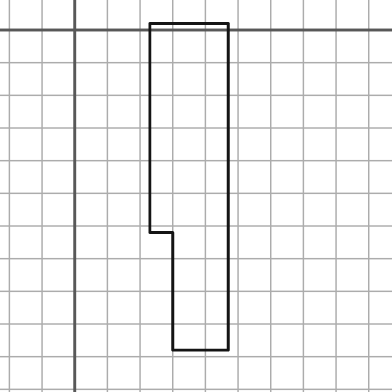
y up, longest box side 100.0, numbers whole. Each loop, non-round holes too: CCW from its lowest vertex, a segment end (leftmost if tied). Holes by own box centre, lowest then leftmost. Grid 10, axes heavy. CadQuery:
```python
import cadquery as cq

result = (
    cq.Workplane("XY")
    .moveTo(30.0, -98.0)
    .lineTo(47.0, -98.0)
    .lineTo(47.0, 2.0)
    .lineTo(23.0, 2.0)
    .lineTo(23.0, -62.0)
    .lineTo(30.0, -62.0)
    .close()
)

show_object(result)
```